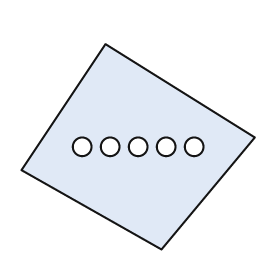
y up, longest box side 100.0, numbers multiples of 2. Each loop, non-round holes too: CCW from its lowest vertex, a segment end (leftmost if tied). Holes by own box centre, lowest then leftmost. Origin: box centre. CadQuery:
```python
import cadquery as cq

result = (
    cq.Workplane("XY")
    .moveTo(10.0, -44.0)
    .lineTo(50.0, 4.0)
    .lineTo(-14.0, 44.0)
    .lineTo(-50.0, -10.0)
    .close()
    .moveTo(-24.0, 0.0)
    .circle(4.0)
    .moveTo(-12.0, 0.0)
    .circle(4.0)
    .moveTo(0.0, 0.0)
    .circle(4.0)
    .moveTo(12.0, 0.0)
    .circle(4.0)
    .moveTo(24.0, 0.0)
    .circle(4.0)
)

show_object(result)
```